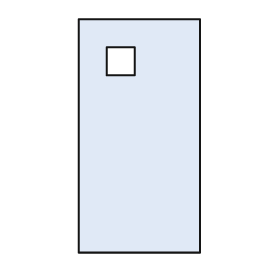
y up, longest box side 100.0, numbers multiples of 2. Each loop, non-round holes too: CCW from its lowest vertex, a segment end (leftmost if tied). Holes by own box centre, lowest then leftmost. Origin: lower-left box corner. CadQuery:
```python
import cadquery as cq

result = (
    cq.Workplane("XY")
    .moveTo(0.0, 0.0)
    .lineTo(52.0, 0.0)
    .lineTo(52.0, 100.0)
    .lineTo(0.0, 100.0)
    .close()
    .moveTo(12.0, 76.0)
    .lineTo(24.0, 76.0)
    .lineTo(24.0, 88.0)
    .lineTo(12.0, 88.0)
    .close()
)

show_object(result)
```